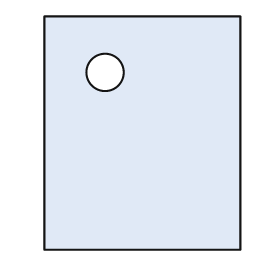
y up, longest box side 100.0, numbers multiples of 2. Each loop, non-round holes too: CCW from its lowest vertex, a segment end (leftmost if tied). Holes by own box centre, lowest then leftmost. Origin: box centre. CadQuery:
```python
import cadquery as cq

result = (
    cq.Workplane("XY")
    .moveTo(-42.0, -50.0)
    .lineTo(42.0, -50.0)
    .lineTo(42.0, 50.0)
    .lineTo(-42.0, 50.0)
    .close()
    .moveTo(-16.0, 26.0)
    .circle(8.0)
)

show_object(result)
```